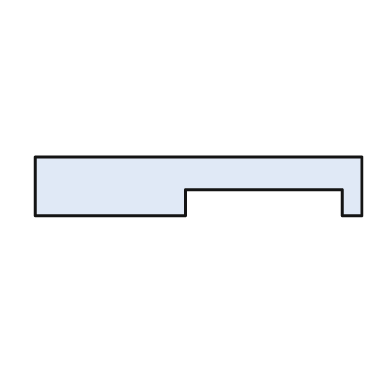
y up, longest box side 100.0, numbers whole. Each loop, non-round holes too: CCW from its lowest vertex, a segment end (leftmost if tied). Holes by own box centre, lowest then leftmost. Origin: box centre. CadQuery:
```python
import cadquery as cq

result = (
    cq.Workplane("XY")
    .moveTo(-50.0, -9.0)
    .lineTo(-4.0, -9.0)
    .lineTo(-4.0, -1.0)
    .lineTo(44.0, -1.0)
    .lineTo(44.0, -9.0)
    .lineTo(50.0, -9.0)
    .lineTo(50.0, 9.0)
    .lineTo(-50.0, 9.0)
    .close()
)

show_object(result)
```